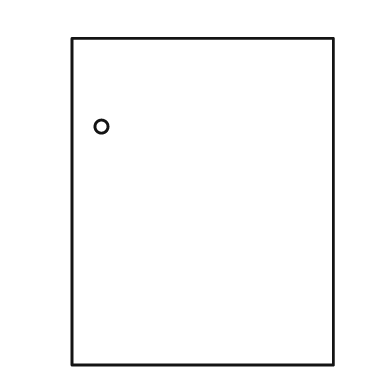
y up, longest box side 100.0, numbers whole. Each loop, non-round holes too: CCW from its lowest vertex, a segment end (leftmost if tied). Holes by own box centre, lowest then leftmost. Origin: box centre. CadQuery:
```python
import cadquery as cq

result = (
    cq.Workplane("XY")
    .moveTo(-40.0, -50.0)
    .lineTo(40.0, -50.0)
    .lineTo(40.0, 50.0)
    .lineTo(-40.0, 50.0)
    .close()
    .moveTo(-31.0, 23.0)
    .circle(2.0)
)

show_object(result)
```